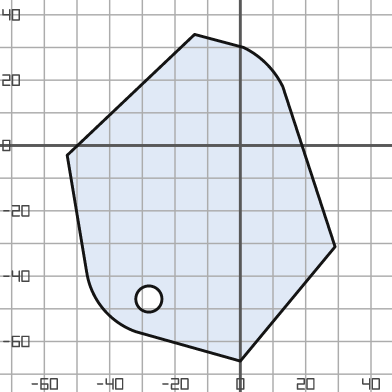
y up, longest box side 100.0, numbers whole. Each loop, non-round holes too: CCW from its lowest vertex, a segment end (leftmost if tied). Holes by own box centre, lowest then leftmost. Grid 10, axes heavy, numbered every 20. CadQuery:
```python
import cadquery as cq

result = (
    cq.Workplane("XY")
    .moveTo(0.0, -66.0)
    .lineTo(29.0, -31.0)
    .lineTo(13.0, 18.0)
    .threePointArc((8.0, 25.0), (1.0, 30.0))
    .lineTo(-14.0, 34.0)
    .lineTo(-53.0, -3.0)
    .lineTo(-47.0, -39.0)
    .threePointArc((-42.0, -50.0), (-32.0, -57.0))
    .close()
    .moveTo(-28.0, -47.0)
    .circle(4.0)
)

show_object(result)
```